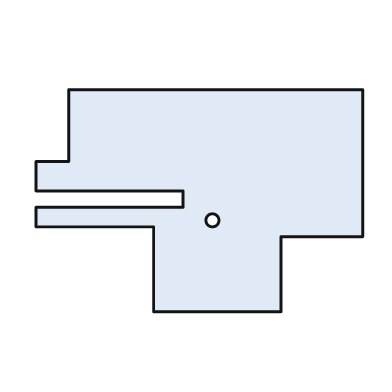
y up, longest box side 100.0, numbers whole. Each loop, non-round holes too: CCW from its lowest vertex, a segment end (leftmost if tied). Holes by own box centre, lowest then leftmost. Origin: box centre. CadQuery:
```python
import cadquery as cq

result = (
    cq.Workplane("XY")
    .moveTo(-14.0, -34.0)
    .lineTo(25.0, -34.0)
    .lineTo(25.0, -11.0)
    .lineTo(50.0, -11.0)
    .lineTo(50.0, 34.0)
    .lineTo(-40.0, 34.0)
    .lineTo(-40.0, 12.0)
    .lineTo(-50.0, 12.0)
    .lineTo(-50.0, 3.0)
    .lineTo(-5.0, 3.0)
    .lineTo(-5.0, -2.0)
    .lineTo(-50.0, -2.0)
    .lineTo(-50.0, -8.0)
    .lineTo(-14.0, -8.0)
    .close()
    .moveTo(4.0, -6.0)
    .circle(2.0)
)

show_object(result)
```